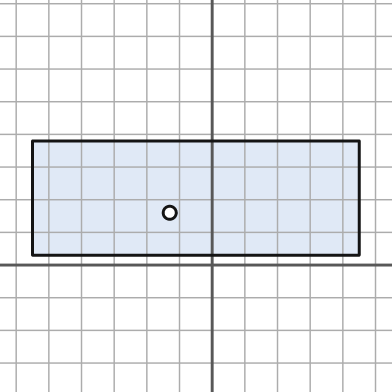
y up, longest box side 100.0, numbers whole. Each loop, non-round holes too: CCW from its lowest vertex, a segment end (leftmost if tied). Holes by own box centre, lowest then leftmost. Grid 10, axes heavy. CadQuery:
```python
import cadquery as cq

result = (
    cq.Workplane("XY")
    .moveTo(-55.0, 3.0)
    .lineTo(45.0, 3.0)
    .lineTo(45.0, 38.0)
    .lineTo(-55.0, 38.0)
    .close()
    .moveTo(-13.0, 16.0)
    .circle(2.0)
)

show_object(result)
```